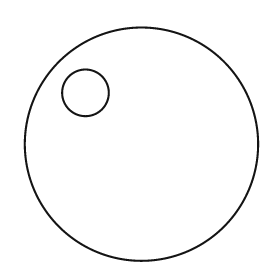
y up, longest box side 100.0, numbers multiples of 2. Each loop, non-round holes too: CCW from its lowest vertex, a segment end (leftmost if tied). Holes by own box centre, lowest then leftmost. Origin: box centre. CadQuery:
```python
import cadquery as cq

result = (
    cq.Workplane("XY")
    .moveTo(0.0, 0.0)
    .circle(50.0)
    .moveTo(-24.0, 22.0)
    .circle(10.0)
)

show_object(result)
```